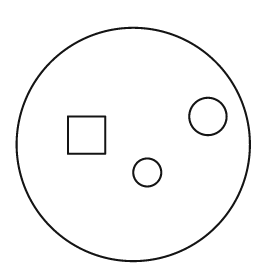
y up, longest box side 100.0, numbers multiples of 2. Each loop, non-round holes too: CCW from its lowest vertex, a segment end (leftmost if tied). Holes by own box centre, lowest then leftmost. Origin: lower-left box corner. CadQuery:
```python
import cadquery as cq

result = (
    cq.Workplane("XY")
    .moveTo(50.0, 50.0)
    .circle(50.0)
    .moveTo(56.0, 38.0)
    .circle(6.0)
    .moveTo(22.0, 46.0)
    .lineTo(38.0, 46.0)
    .lineTo(38.0, 62.0)
    .lineTo(22.0, 62.0)
    .close()
    .moveTo(82.0, 62.0)
    .circle(8.0)
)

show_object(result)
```